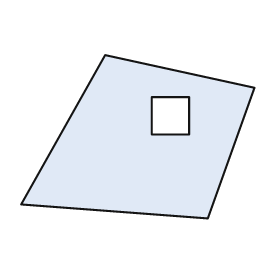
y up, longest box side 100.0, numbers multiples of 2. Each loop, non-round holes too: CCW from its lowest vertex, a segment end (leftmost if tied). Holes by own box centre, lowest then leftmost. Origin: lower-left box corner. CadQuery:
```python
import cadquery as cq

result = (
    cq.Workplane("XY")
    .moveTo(80.0, 0.0)
    .lineTo(100.0, 56.0)
    .lineTo(36.0, 70.0)
    .lineTo(0.0, 6.0)
    .close()
    .moveTo(56.0, 36.0)
    .lineTo(72.0, 36.0)
    .lineTo(72.0, 52.0)
    .lineTo(56.0, 52.0)
    .close()
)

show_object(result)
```